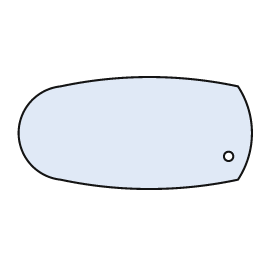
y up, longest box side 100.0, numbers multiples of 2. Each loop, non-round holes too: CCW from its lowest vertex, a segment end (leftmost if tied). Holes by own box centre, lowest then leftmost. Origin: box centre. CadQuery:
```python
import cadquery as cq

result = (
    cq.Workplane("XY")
    .moveTo(-32.0, -20.0)
    .threePointArc((6.0, -24.0), (44.0, -20.0))
    .threePointArc((50.0, 0.0), (44.0, 20.0))
    .threePointArc((6.0, 24.0), (-32.0, 20.0))
    .threePointArc((-50.0, 0.0), (-32.0, -20.0))
    .close()
    .moveTo(40.0, -10.0)
    .circle(2.0)
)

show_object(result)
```